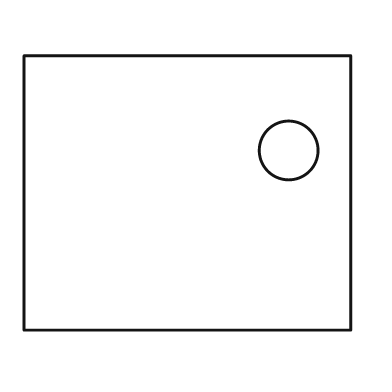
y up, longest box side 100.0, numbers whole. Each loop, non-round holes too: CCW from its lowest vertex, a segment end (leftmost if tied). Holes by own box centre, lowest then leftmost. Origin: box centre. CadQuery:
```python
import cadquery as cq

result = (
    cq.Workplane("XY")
    .moveTo(-50.0, -42.0)
    .lineTo(50.0, -42.0)
    .lineTo(50.0, 42.0)
    .lineTo(-50.0, 42.0)
    .close()
    .moveTo(31.0, 13.0)
    .circle(9.0)
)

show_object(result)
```